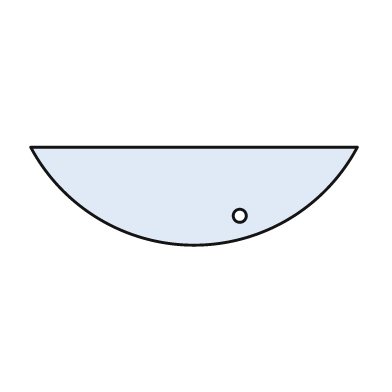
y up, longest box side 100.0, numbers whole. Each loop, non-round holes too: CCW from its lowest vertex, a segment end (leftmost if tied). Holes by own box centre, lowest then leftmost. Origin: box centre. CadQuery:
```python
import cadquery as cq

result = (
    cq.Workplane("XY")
    .moveTo(-50.0, 15.0)
    .threePointArc((0.0, -15.0), (50.0, 15.0))
    .close()
    .moveTo(14.0, -6.0)
    .circle(2.0)
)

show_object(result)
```